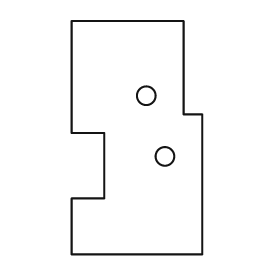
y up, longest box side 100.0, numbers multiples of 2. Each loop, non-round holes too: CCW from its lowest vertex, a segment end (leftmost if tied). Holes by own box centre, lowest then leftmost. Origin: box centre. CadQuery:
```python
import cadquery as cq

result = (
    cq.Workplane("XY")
    .moveTo(-28.0, -50.0)
    .lineTo(28.0, -50.0)
    .lineTo(28.0, 10.0)
    .lineTo(20.0, 10.0)
    .lineTo(20.0, 50.0)
    .lineTo(-28.0, 50.0)
    .lineTo(-28.0, 2.0)
    .lineTo(-14.0, 2.0)
    .lineTo(-14.0, -26.0)
    .lineTo(-28.0, -26.0)
    .close()
    .moveTo(12.0, -8.0)
    .circle(4.0)
    .moveTo(4.0, 18.0)
    .circle(4.0)
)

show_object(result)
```